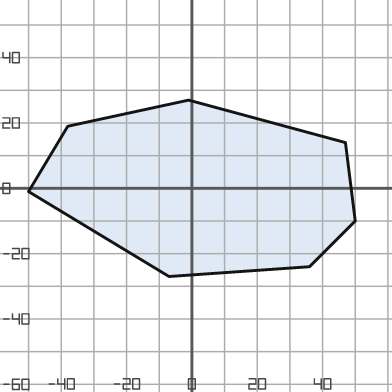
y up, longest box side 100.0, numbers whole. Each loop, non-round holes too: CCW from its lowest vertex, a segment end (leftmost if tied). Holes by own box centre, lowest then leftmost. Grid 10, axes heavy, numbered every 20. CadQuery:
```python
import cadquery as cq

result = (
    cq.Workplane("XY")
    .moveTo(-7.0, -27.0)
    .lineTo(36.0, -24.0)
    .lineTo(50.0, -10.0)
    .lineTo(47.0, 14.0)
    .lineTo(-1.0, 27.0)
    .lineTo(-38.0, 19.0)
    .lineTo(-50.0, -1.0)
    .close()
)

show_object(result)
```